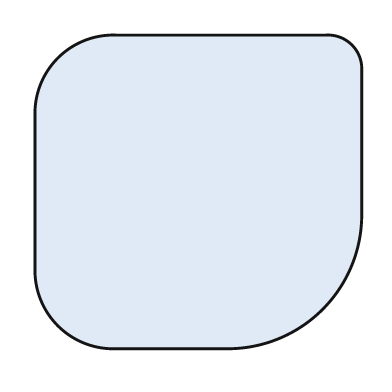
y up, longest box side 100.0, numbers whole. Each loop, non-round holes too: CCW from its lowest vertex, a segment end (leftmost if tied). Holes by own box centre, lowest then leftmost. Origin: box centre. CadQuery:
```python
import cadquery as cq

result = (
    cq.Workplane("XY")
    .moveTo(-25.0, -48.0)
    .lineTo(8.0, -48.0)
    .threePointArc((38.0, -36.0), (50.0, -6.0))
    .lineTo(50.0, 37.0)
    .threePointArc((47.0, 45.0), (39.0, 48.0))
    .lineTo(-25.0, 48.0)
    .threePointArc((-43.0, 41.0), (-50.0, 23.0))
    .lineTo(-50.0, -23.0)
    .threePointArc((-43.0, -41.0), (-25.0, -48.0))
    .close()
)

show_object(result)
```